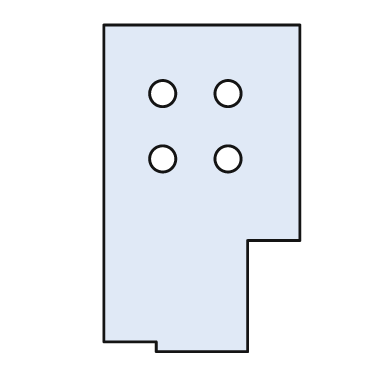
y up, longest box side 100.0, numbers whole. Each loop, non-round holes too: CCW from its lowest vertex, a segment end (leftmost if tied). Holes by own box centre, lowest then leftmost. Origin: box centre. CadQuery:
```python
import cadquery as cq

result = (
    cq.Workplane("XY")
    .moveTo(-14.0, -50.0)
    .lineTo(14.0, -50.0)
    .lineTo(14.0, -16.0)
    .lineTo(30.0, -16.0)
    .lineTo(30.0, 50.0)
    .lineTo(-30.0, 50.0)
    .lineTo(-30.0, -47.0)
    .lineTo(-14.0, -47.0)
    .close()
    .moveTo(-12.0, 9.0)
    .circle(4.0)
    .moveTo(8.0, 9.0)
    .circle(4.0)
    .moveTo(-12.0, 29.0)
    .circle(4.0)
    .moveTo(8.0, 29.0)
    .circle(4.0)
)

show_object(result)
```